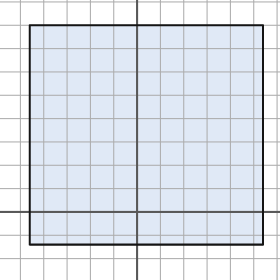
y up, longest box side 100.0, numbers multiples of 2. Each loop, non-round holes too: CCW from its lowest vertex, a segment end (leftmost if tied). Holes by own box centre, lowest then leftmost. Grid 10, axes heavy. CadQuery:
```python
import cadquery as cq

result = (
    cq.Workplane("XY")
    .moveTo(-46.0, -14.0)
    .lineTo(54.0, -14.0)
    .lineTo(54.0, 80.0)
    .lineTo(-46.0, 80.0)
    .close()
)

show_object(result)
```